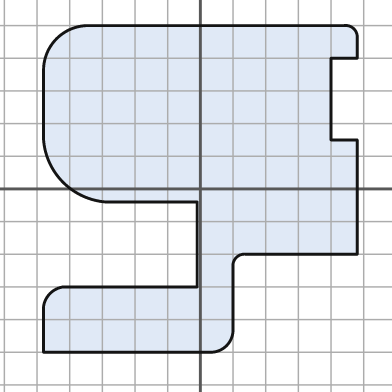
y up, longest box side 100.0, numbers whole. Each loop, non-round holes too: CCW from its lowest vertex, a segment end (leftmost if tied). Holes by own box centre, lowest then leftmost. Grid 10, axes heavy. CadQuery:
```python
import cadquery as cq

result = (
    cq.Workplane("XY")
    .moveTo(-48.0, -50.0)
    .lineTo(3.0, -50.0)
    .threePointArc((8.0, -48.0), (10.0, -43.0))
    .lineTo(10.0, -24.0)
    .threePointArc((11.0, -21.0), (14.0, -20.0))
    .lineTo(48.0, -20.0)
    .lineTo(48.0, 15.0)
    .lineTo(40.0, 15.0)
    .lineTo(40.0, 40.0)
    .lineTo(48.0, 40.0)
    .lineTo(48.0, 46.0)
    .threePointArc((47.0, 49.0), (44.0, 50.0))
    .lineTo(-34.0, 50.0)
    .threePointArc((-44.0, 46.0), (-48.0, 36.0))
    .lineTo(-48.0, 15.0)
    .threePointArc((-42.0, 2.0), (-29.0, -4.0))
    .lineTo(-1.0, -4.0)
    .lineTo(-1.0, -30.0)
    .lineTo(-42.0, -30.0)
    .threePointArc((-46.0, -32.0), (-48.0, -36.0))
    .close()
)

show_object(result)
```